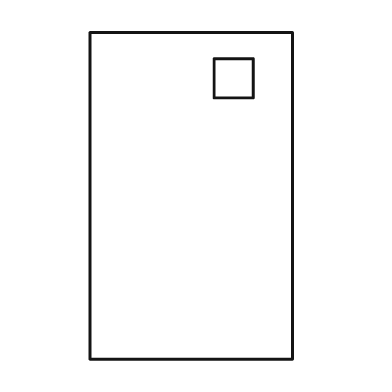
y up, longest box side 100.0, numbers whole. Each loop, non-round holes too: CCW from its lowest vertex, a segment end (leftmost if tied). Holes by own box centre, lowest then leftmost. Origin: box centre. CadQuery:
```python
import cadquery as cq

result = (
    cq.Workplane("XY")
    .moveTo(-31.0, -50.0)
    .lineTo(31.0, -50.0)
    .lineTo(31.0, 50.0)
    .lineTo(-31.0, 50.0)
    .close()
    .moveTo(7.0, 30.0)
    .lineTo(19.0, 30.0)
    .lineTo(19.0, 42.0)
    .lineTo(7.0, 42.0)
    .close()
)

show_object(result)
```